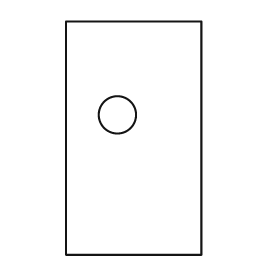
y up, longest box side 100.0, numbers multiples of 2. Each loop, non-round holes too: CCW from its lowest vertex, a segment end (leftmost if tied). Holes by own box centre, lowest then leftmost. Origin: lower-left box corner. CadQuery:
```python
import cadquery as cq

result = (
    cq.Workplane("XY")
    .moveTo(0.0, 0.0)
    .lineTo(58.0, 0.0)
    .lineTo(58.0, 100.0)
    .lineTo(0.0, 100.0)
    .close()
    .moveTo(22.0, 60.0)
    .circle(8.0)
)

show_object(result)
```